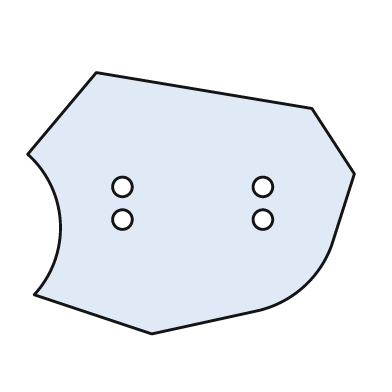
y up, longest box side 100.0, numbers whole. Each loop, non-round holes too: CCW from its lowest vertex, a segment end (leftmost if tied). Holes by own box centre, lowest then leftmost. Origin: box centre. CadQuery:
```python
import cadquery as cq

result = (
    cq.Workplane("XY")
    .moveTo(-12.0, -40.0)
    .lineTo(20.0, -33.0)
    .threePointArc((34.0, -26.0), (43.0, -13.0))
    .lineTo(50.0, 9.0)
    .lineTo(37.0, 29.0)
    .lineTo(-29.0, 40.0)
    .lineTo(-50.0, 15.0)
    .threePointArc((-40.0, -6.0), (-48.0, -28.0))
    .close()
    .moveTo(-21.0, -5.0)
    .circle(3.0)
    .moveTo(22.0, -5.0)
    .circle(3.0)
    .moveTo(-21.0, 5.0)
    .circle(3.0)
    .moveTo(22.0, 5.0)
    .circle(3.0)
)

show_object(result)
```